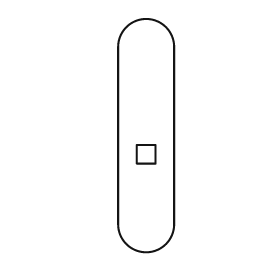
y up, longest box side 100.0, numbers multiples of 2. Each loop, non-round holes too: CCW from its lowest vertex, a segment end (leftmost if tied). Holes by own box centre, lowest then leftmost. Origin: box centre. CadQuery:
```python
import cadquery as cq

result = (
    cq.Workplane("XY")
    .moveTo(-12.0, -38.0)
    .threePointArc((0.0, -50.0), (12.0, -38.0))
    .lineTo(12.0, 38.0)
    .threePointArc((0.0, 50.0), (-12.0, 38.0))
    .close()
    .moveTo(-4.0, -12.0)
    .lineTo(4.0, -12.0)
    .lineTo(4.0, -4.0)
    .lineTo(-4.0, -4.0)
    .close()
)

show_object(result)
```